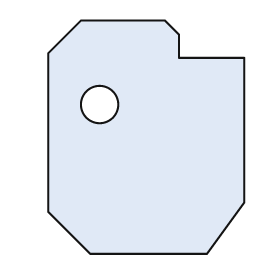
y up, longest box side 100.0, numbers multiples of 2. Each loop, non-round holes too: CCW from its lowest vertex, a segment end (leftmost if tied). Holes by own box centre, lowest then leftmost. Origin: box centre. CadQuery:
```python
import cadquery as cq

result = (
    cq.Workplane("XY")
    .moveTo(-24.0, -50.0)
    .lineTo(26.0, -50.0)
    .lineTo(42.0, -28.0)
    .lineTo(42.0, 34.0)
    .lineTo(14.0, 34.0)
    .lineTo(14.0, 44.0)
    .lineTo(8.0, 50.0)
    .lineTo(-28.0, 50.0)
    .lineTo(-42.0, 36.0)
    .lineTo(-42.0, -32.0)
    .close()
    .moveTo(-20.0, 14.0)
    .circle(8.0)
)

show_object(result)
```